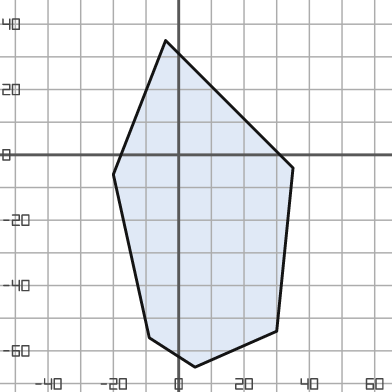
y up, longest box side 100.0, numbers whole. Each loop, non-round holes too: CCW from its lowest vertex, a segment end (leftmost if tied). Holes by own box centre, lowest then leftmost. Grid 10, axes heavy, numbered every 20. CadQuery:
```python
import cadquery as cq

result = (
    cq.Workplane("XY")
    .moveTo(5.0, -65.0)
    .lineTo(30.0, -54.0)
    .lineTo(35.0, -4.0)
    .lineTo(-4.0, 35.0)
    .lineTo(-20.0, -6.0)
    .lineTo(-9.0, -56.0)
    .close()
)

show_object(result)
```